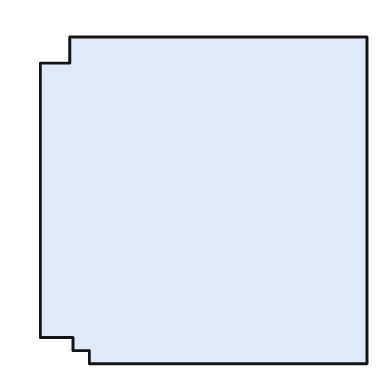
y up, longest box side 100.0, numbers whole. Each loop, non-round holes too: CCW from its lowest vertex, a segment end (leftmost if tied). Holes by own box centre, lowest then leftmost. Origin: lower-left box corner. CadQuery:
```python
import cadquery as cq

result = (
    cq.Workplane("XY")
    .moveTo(15.0, 0.0)
    .lineTo(100.0, 0.0)
    .lineTo(100.0, 100.0)
    .lineTo(9.0, 100.0)
    .lineTo(9.0, 92.0)
    .lineTo(0.0, 92.0)
    .lineTo(0.0, 8.0)
    .lineTo(10.0, 8.0)
    .lineTo(10.0, 4.0)
    .lineTo(15.0, 4.0)
    .close()
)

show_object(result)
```